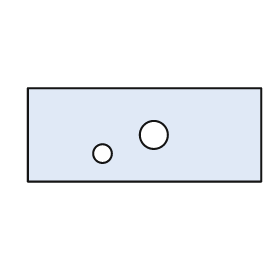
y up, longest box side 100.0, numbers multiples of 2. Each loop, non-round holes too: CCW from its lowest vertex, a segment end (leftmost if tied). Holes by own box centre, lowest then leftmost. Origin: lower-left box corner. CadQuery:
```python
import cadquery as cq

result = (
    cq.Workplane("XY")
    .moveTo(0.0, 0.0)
    .lineTo(100.0, 0.0)
    .lineTo(100.0, 40.0)
    .lineTo(0.0, 40.0)
    .close()
    .moveTo(32.0, 12.0)
    .circle(4.0)
    .moveTo(54.0, 20.0)
    .circle(6.0)
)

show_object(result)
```